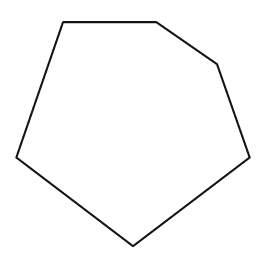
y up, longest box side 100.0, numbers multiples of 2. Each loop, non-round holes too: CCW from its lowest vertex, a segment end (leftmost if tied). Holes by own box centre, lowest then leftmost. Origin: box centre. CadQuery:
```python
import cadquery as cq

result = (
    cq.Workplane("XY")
    .moveTo(0.0, -48.0)
    .lineTo(50.0, -10.0)
    .lineTo(36.0, 30.0)
    .lineTo(10.0, 48.0)
    .lineTo(-30.0, 48.0)
    .lineTo(-50.0, -10.0)
    .close()
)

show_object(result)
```